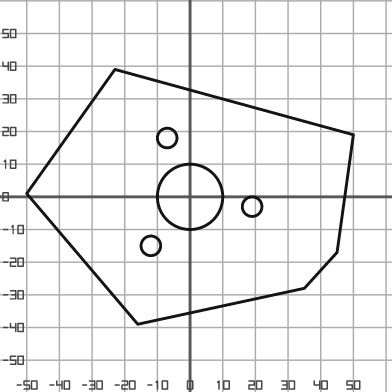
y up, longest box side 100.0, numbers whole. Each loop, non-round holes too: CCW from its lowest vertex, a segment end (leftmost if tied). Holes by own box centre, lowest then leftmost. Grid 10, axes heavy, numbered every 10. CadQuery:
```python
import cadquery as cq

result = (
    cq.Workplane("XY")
    .moveTo(-16.0, -39.0)
    .lineTo(35.0, -28.0)
    .lineTo(45.0, -17.0)
    .lineTo(50.0, 19.0)
    .lineTo(-23.0, 39.0)
    .lineTo(-50.0, 1.0)
    .close()
    .moveTo(-12.0, -15.0)
    .circle(3.0)
    .moveTo(19.0, -3.0)
    .circle(3.0)
    .moveTo(0.0, 0.0)
    .circle(10.0)
    .moveTo(-7.0, 18.0)
    .circle(3.0)
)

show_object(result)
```